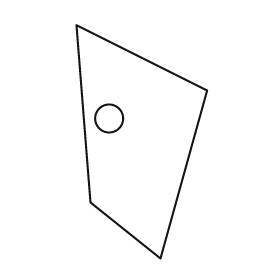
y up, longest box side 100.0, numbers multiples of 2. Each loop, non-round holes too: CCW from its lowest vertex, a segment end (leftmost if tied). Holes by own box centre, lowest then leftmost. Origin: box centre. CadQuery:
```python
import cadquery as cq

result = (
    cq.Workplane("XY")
    .moveTo(8.0, -50.0)
    .lineTo(28.0, 22.0)
    .lineTo(-28.0, 50.0)
    .lineTo(-22.0, -26.0)
    .close()
    .moveTo(-14.0, 10.0)
    .circle(6.0)
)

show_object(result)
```